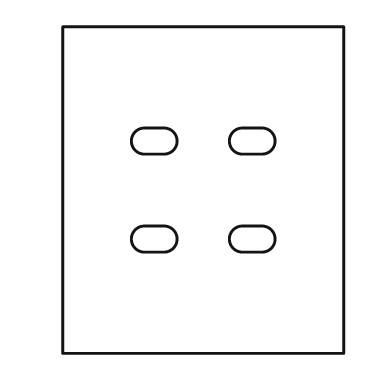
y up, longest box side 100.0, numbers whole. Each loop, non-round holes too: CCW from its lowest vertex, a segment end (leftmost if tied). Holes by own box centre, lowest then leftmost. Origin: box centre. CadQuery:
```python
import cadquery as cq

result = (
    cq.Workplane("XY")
    .moveTo(-43.0, -50.0)
    .lineTo(43.0, -50.0)
    .lineTo(43.0, 50.0)
    .lineTo(-43.0, 50.0)
    .close()
    .moveTo(-18.0, -19.0)
    .lineTo(-12.0, -19.0)
    .threePointArc((-8.0, -15.0), (-12.0, -11.0))
    .lineTo(-18.0, -11.0)
    .threePointArc((-22.0, -15.0), (-18.0, -19.0))
    .close()
    .moveTo(12.0, -19.0)
    .lineTo(18.0, -19.0)
    .threePointArc((22.0, -15.0), (18.0, -11.0))
    .lineTo(12.0, -11.0)
    .threePointArc((8.0, -15.0), (12.0, -19.0))
    .close()
    .moveTo(-18.0, 11.0)
    .lineTo(-12.0, 11.0)
    .threePointArc((-8.0, 15.0), (-12.0, 19.0))
    .lineTo(-18.0, 19.0)
    .threePointArc((-22.0, 15.0), (-18.0, 11.0))
    .close()
    .moveTo(12.0, 11.0)
    .lineTo(18.0, 11.0)
    .threePointArc((22.0, 15.0), (18.0, 19.0))
    .lineTo(12.0, 19.0)
    .threePointArc((8.0, 15.0), (12.0, 11.0))
    .close()
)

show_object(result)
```